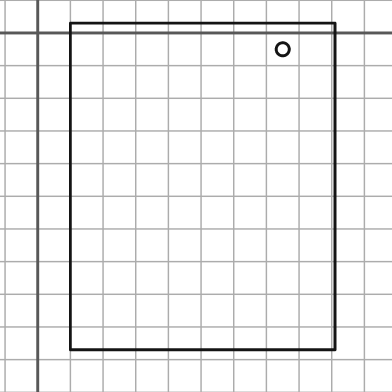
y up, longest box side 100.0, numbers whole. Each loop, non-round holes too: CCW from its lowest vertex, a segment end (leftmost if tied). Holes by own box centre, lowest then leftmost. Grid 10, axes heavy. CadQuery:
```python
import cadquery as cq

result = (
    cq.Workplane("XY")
    .moveTo(10.0, -97.0)
    .lineTo(91.0, -97.0)
    .lineTo(91.0, 3.0)
    .lineTo(10.0, 3.0)
    .close()
    .moveTo(75.0, -5.0)
    .circle(2.0)
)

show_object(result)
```